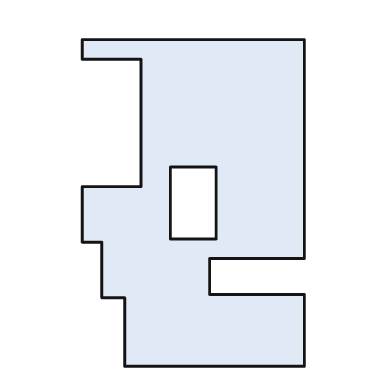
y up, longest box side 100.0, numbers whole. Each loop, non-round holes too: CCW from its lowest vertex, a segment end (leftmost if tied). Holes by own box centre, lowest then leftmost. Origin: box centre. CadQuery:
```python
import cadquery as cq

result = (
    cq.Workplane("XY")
    .moveTo(-21.0, -50.0)
    .lineTo(34.0, -50.0)
    .lineTo(34.0, -28.0)
    .lineTo(5.0, -28.0)
    .lineTo(5.0, -17.0)
    .lineTo(34.0, -17.0)
    .lineTo(34.0, 50.0)
    .lineTo(-34.0, 50.0)
    .lineTo(-34.0, 44.0)
    .lineTo(-16.0, 44.0)
    .lineTo(-16.0, 5.0)
    .lineTo(-34.0, 5.0)
    .lineTo(-34.0, -12.0)
    .lineTo(-28.0, -12.0)
    .lineTo(-28.0, -29.0)
    .lineTo(-21.0, -29.0)
    .close()
    .moveTo(-7.0, -11.0)
    .lineTo(7.0, -11.0)
    .lineTo(7.0, 11.0)
    .lineTo(-7.0, 11.0)
    .close()
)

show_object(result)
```